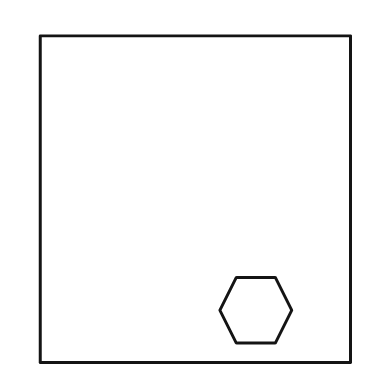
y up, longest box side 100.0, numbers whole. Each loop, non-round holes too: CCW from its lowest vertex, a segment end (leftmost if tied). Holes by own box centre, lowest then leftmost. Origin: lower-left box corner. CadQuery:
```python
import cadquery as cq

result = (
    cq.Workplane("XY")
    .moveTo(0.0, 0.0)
    .lineTo(95.0, 0.0)
    .lineTo(95.0, 100.0)
    .lineTo(0.0, 100.0)
    .close()
    .moveTo(60.0, 6.0)
    .lineTo(72.0, 6.0)
    .lineTo(77.0, 16.0)
    .lineTo(72.0, 26.0)
    .lineTo(60.0, 26.0)
    .lineTo(55.0, 16.0)
    .close()
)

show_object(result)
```